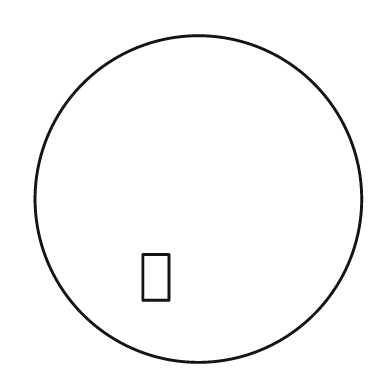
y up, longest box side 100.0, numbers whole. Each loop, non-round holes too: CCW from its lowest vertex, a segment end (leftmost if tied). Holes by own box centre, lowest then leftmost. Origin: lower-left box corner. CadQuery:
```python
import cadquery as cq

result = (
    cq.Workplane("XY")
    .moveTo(50.0, 50.0)
    .circle(50.0)
    .moveTo(33.0, 19.0)
    .lineTo(41.0, 19.0)
    .lineTo(41.0, 33.0)
    .lineTo(33.0, 33.0)
    .close()
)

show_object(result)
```